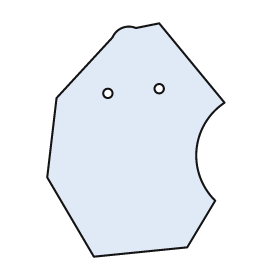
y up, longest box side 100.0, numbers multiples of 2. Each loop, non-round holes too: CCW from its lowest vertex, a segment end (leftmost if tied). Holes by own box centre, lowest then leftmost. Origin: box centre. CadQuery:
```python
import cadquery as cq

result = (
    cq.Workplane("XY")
    .moveTo(-18.0, -50.0)
    .lineTo(22.0, -46.0)
    .lineTo(34.0, -26.0)
    .threePointArc((26.0, -4.0), (38.0, 16.0))
    .lineTo(10.0, 50.0)
    .lineTo(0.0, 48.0)
    .threePointArc((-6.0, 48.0), (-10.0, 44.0))
    .lineTo(-34.0, 18.0)
    .lineTo(-38.0, -16.0)
    .close()
    .moveTo(-12.0, 20.0)
    .circle(2.0)
    .moveTo(10.0, 22.0)
    .circle(2.0)
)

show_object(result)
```